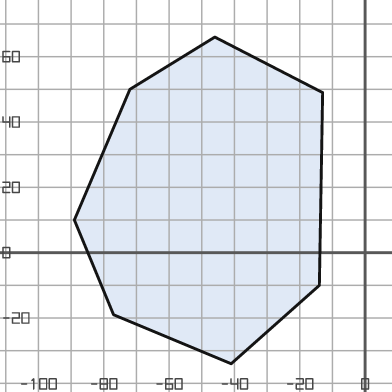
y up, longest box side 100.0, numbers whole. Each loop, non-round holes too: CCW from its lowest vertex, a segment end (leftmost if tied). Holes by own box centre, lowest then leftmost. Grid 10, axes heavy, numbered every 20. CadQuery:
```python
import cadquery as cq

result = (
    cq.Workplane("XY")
    .moveTo(-41.0, -34.0)
    .lineTo(-14.0, -10.0)
    .lineTo(-13.0, 49.0)
    .lineTo(-46.0, 66.0)
    .lineTo(-72.0, 50.0)
    .lineTo(-89.0, 10.0)
    .lineTo(-77.0, -19.0)
    .close()
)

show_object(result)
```